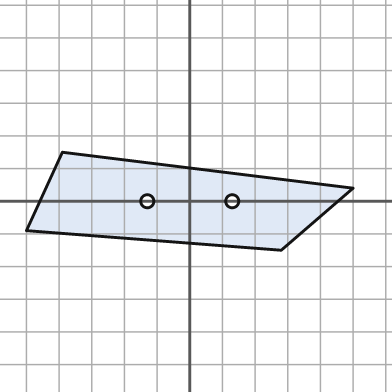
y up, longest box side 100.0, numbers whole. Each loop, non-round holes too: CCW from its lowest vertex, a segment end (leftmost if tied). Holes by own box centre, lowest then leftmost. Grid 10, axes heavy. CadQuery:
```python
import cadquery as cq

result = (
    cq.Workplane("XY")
    .moveTo(28.0, -15.0)
    .lineTo(50.0, 4.0)
    .lineTo(-39.0, 15.0)
    .lineTo(-50.0, -9.0)
    .close()
    .moveTo(-13.0, 0.0)
    .circle(2.0)
    .moveTo(13.0, 0.0)
    .circle(2.0)
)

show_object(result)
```